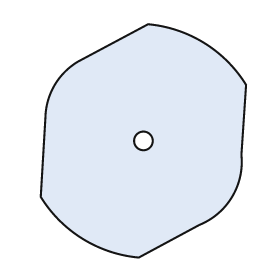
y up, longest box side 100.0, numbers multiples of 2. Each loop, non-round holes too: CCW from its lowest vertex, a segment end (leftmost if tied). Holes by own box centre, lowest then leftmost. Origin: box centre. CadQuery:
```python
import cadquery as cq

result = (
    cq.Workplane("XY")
    .moveTo(-2.0, -50.0)
    .lineTo(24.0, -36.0)
    .threePointArc((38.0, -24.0), (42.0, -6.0))
    .lineTo(44.0, 24.0)
    .threePointArc((26.0, 42.0), (2.0, 50.0))
    .lineTo(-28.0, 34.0)
    .threePointArc((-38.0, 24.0), (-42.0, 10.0))
    .lineTo(-44.0, -24.0)
    .threePointArc((-26.0, -42.0), (-2.0, -50.0))
    .close()
    .moveTo(0.0, 0.0)
    .circle(4.0)
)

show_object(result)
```